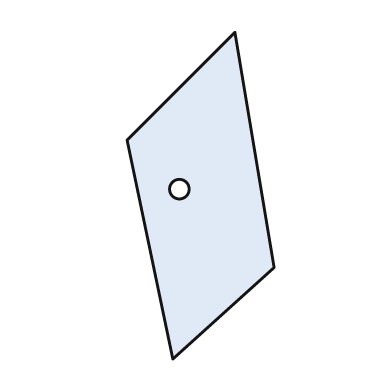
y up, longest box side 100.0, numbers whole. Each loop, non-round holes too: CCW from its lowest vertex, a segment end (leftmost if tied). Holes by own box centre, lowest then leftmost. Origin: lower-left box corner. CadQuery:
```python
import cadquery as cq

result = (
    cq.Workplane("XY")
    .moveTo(14.0, 0.0)
    .lineTo(45.0, 28.0)
    .lineTo(33.0, 100.0)
    .lineTo(0.0, 67.0)
    .close()
    .moveTo(16.0, 52.0)
    .circle(3.0)
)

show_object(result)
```